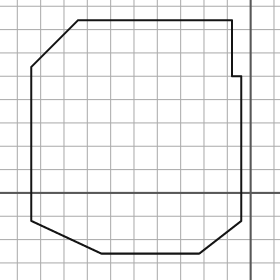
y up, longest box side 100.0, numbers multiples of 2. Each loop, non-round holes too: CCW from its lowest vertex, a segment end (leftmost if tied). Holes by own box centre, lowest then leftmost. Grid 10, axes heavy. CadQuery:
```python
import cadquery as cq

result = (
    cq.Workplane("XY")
    .moveTo(-64.0, -26.0)
    .lineTo(-22.0, -26.0)
    .lineTo(-4.0, -12.0)
    .lineTo(-4.0, 50.0)
    .lineTo(-8.0, 50.0)
    .lineTo(-8.0, 74.0)
    .lineTo(-74.0, 74.0)
    .lineTo(-94.0, 54.0)
    .lineTo(-94.0, -12.0)
    .close()
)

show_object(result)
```